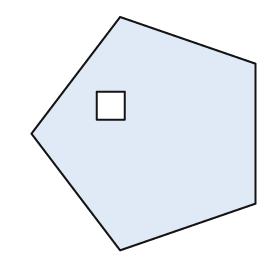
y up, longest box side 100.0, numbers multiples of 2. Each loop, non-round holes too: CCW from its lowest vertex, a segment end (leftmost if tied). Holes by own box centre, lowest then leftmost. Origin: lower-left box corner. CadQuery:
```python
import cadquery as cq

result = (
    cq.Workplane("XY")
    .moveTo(38.0, 0.0)
    .lineTo(96.0, 20.0)
    .lineTo(96.0, 80.0)
    .lineTo(38.0, 100.0)
    .lineTo(0.0, 50.0)
    .close()
    .moveTo(28.0, 56.0)
    .lineTo(40.0, 56.0)
    .lineTo(40.0, 68.0)
    .lineTo(28.0, 68.0)
    .close()
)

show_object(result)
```